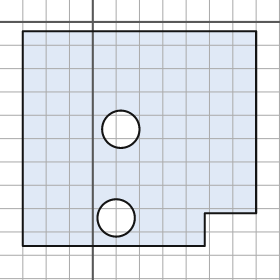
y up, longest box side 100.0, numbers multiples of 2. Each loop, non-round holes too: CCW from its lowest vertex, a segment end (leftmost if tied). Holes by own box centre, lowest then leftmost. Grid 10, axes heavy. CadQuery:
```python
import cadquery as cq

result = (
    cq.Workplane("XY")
    .moveTo(-30.0, -96.0)
    .lineTo(48.0, -96.0)
    .lineTo(48.0, -82.0)
    .lineTo(70.0, -82.0)
    .lineTo(70.0, -4.0)
    .lineTo(-30.0, -4.0)
    .close()
    .moveTo(10.0, -84.0)
    .circle(8.0)
    .moveTo(12.0, -46.0)
    .circle(8.0)
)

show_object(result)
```